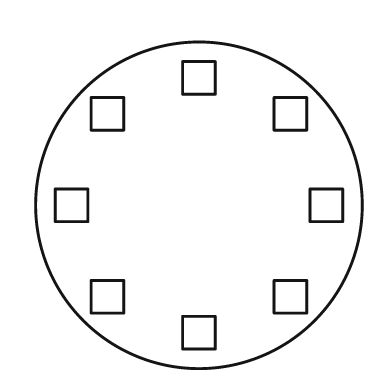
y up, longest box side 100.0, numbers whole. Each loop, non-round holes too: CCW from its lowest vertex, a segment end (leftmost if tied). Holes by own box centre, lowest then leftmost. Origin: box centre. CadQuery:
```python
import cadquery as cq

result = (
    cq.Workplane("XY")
    .moveTo(0.0, 0.0)
    .circle(50.0)
    .moveTo(-5.0, -44.0)
    .lineTo(5.0, -44.0)
    .lineTo(5.0, -34.0)
    .lineTo(-5.0, -34.0)
    .close()
    .moveTo(-33.0, -33.0)
    .lineTo(-23.0, -33.0)
    .lineTo(-23.0, -23.0)
    .lineTo(-33.0, -23.0)
    .close()
    .moveTo(23.0, -33.0)
    .lineTo(33.0, -33.0)
    .lineTo(33.0, -23.0)
    .lineTo(23.0, -23.0)
    .close()
    .moveTo(-44.0, -5.0)
    .lineTo(-34.0, -5.0)
    .lineTo(-34.0, 5.0)
    .lineTo(-44.0, 5.0)
    .close()
    .moveTo(34.0, -5.0)
    .lineTo(44.0, -5.0)
    .lineTo(44.0, 5.0)
    .lineTo(34.0, 5.0)
    .close()
    .moveTo(-33.0, 23.0)
    .lineTo(-23.0, 23.0)
    .lineTo(-23.0, 33.0)
    .lineTo(-33.0, 33.0)
    .close()
    .moveTo(23.0, 23.0)
    .lineTo(33.0, 23.0)
    .lineTo(33.0, 33.0)
    .lineTo(23.0, 33.0)
    .close()
    .moveTo(-5.0, 34.0)
    .lineTo(5.0, 34.0)
    .lineTo(5.0, 44.0)
    .lineTo(-5.0, 44.0)
    .close()
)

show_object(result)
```